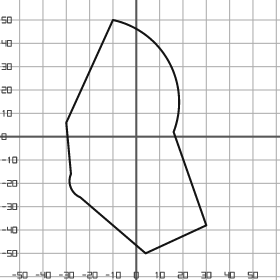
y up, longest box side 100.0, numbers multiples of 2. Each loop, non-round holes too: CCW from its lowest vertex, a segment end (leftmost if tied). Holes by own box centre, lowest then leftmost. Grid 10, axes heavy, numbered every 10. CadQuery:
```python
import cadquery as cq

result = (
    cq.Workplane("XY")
    .moveTo(4.0, -50.0)
    .lineTo(30.0, -38.0)
    .lineTo(16.0, 2.0)
    .threePointArc((14.0, 32.0), (-10.0, 50.0))
    .lineTo(-30.0, 6.0)
    .lineTo(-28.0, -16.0)
    .threePointArc((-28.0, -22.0), (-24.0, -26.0))
    .close()
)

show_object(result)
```